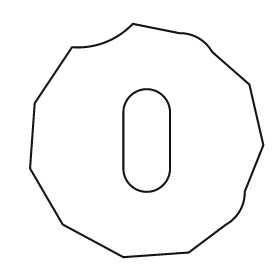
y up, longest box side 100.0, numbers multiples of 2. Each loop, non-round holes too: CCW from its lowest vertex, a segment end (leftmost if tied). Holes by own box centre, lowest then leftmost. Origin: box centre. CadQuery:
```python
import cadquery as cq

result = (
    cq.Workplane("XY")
    .moveTo(-10.0, -50.0)
    .lineTo(18.0, -48.0)
    .lineTo(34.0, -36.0)
    .threePointArc((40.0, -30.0), (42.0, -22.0))
    .lineTo(50.0, -2.0)
    .lineTo(44.0, 24.0)
    .lineTo(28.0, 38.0)
    .threePointArc((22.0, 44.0), (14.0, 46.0))
    .lineTo(-6.0, 50.0)
    .threePointArc((-18.0, 42.0), (-32.0, 40.0))
    .lineTo(-48.0, 16.0)
    .lineTo(-50.0, -12.0)
    .lineTo(-36.0, -36.0)
    .close()
    .moveTo(-10.0, -12.0)
    .threePointArc((0.0, -22.0), (10.0, -12.0))
    .lineTo(10.0, 12.0)
    .threePointArc((0.0, 22.0), (-10.0, 12.0))
    .close()
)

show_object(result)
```